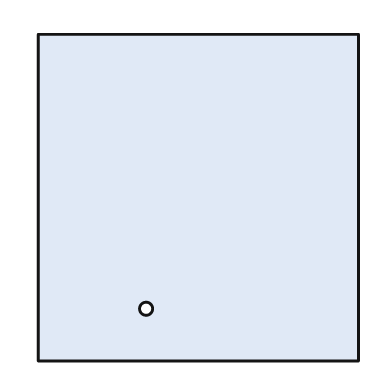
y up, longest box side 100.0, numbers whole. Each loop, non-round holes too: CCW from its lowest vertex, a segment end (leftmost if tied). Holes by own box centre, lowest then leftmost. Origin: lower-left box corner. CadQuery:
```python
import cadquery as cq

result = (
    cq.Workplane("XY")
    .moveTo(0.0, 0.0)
    .lineTo(98.0, 0.0)
    .lineTo(98.0, 100.0)
    .lineTo(0.0, 100.0)
    .close()
    .moveTo(33.0, 16.0)
    .circle(2.0)
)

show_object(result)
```